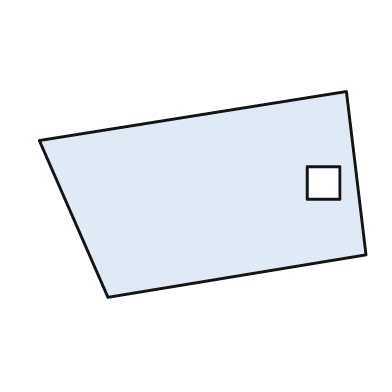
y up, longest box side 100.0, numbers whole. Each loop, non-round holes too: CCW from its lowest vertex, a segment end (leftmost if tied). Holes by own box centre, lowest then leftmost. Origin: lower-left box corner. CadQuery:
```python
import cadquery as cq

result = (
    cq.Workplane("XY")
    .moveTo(21.0, 0.0)
    .lineTo(100.0, 13.0)
    .lineTo(94.0, 63.0)
    .lineTo(0.0, 48.0)
    .close()
    .moveTo(82.0, 30.0)
    .lineTo(92.0, 30.0)
    .lineTo(92.0, 40.0)
    .lineTo(82.0, 40.0)
    .close()
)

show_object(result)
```